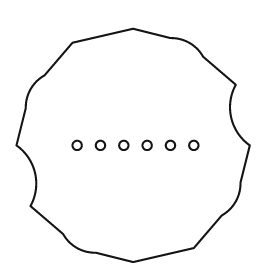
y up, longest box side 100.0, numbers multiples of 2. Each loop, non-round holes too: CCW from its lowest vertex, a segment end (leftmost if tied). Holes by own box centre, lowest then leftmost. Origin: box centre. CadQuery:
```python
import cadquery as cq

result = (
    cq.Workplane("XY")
    .moveTo(0.0, -50.0)
    .lineTo(26.0, -44.0)
    .lineTo(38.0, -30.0)
    .threePointArc((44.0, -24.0), (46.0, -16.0))
    .lineTo(50.0, 0.0)
    .threePointArc((42.0, 12.0), (44.0, 26.0))
    .lineTo(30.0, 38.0)
    .threePointArc((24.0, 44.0), (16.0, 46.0))
    .lineTo(0.0, 50.0)
    .lineTo(-26.0, 44.0)
    .lineTo(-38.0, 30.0)
    .threePointArc((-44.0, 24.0), (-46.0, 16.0))
    .lineTo(-50.0, 0.0)
    .threePointArc((-42.0, -12.0), (-44.0, -26.0))
    .lineTo(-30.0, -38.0)
    .threePointArc((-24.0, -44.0), (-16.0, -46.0))
    .close()
    .moveTo(-24.0, 0.0)
    .circle(2.0)
    .moveTo(-14.0, 0.0)
    .circle(2.0)
    .moveTo(-4.0, 0.0)
    .circle(2.0)
    .moveTo(6.0, 0.0)
    .circle(2.0)
    .moveTo(16.0, 0.0)
    .circle(2.0)
    .moveTo(26.0, 0.0)
    .circle(2.0)
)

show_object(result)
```